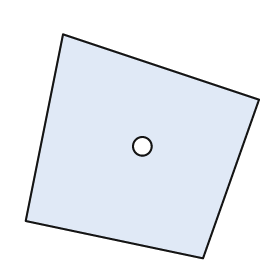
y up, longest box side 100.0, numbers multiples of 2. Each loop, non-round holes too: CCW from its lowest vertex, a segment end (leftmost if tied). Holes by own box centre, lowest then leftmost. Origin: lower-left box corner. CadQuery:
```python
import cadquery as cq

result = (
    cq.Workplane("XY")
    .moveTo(76.0, 0.0)
    .lineTo(100.0, 68.0)
    .lineTo(16.0, 96.0)
    .lineTo(0.0, 16.0)
    .close()
    .moveTo(50.0, 48.0)
    .circle(4.0)
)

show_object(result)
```